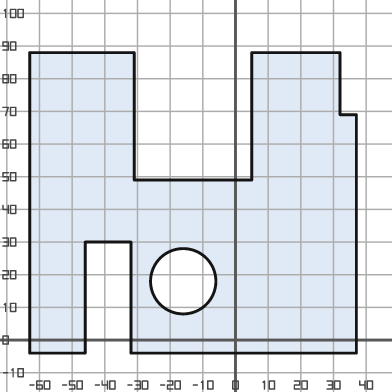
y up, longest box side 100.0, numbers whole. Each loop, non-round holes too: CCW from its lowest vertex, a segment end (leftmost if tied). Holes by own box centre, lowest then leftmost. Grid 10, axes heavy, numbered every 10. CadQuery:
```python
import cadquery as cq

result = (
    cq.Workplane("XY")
    .moveTo(-63.0, -4.0)
    .lineTo(-46.0, -4.0)
    .lineTo(-46.0, 30.0)
    .lineTo(-32.0, 30.0)
    .lineTo(-32.0, -4.0)
    .lineTo(37.0, -4.0)
    .lineTo(37.0, 69.0)
    .lineTo(32.0, 69.0)
    .lineTo(32.0, 88.0)
    .lineTo(5.0, 88.0)
    .lineTo(5.0, 49.0)
    .lineTo(-31.0, 49.0)
    .lineTo(-31.0, 88.0)
    .lineTo(-63.0, 88.0)
    .close()
    .moveTo(-16.0, 18.0)
    .circle(10.0)
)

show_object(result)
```